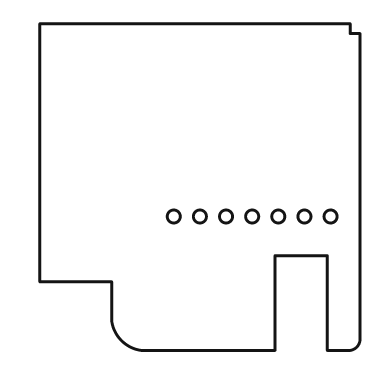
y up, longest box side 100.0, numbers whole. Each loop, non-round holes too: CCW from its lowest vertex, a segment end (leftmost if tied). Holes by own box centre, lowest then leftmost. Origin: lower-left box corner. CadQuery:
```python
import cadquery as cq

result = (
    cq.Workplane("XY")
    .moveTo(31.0, 0.0)
    .lineTo(72.0, 0.0)
    .lineTo(72.0, 29.0)
    .lineTo(88.0, 29.0)
    .lineTo(88.0, 0.0)
    .lineTo(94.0, 0.0)
    .threePointArc((97.0, 1.0), (98.0, 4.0))
    .lineTo(98.0, 97.0)
    .lineTo(95.0, 97.0)
    .lineTo(95.0, 100.0)
    .lineTo(0.0, 100.0)
    .lineTo(0.0, 21.0)
    .lineTo(22.0, 21.0)
    .lineTo(22.0, 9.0)
    .threePointArc((25.0, 3.0), (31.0, 0.0))
    .close()
    .moveTo(41.0, 41.0)
    .circle(2.0)
    .moveTo(49.0, 41.0)
    .circle(2.0)
    .moveTo(57.0, 41.0)
    .circle(2.0)
    .moveTo(65.0, 41.0)
    .circle(2.0)
    .moveTo(73.0, 41.0)
    .circle(2.0)
    .moveTo(81.0, 41.0)
    .circle(2.0)
    .moveTo(89.0, 41.0)
    .circle(2.0)
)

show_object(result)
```